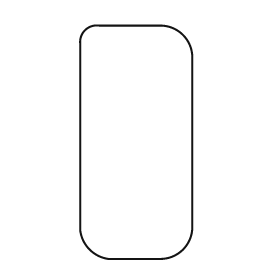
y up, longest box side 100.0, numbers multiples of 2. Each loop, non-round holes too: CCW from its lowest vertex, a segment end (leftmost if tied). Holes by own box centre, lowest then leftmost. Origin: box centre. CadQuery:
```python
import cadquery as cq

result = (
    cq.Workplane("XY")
    .moveTo(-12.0, -50.0)
    .lineTo(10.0, -50.0)
    .threePointArc((20.0, -46.0), (24.0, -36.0))
    .lineTo(24.0, 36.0)
    .threePointArc((20.0, 46.0), (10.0, 50.0))
    .lineTo(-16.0, 50.0)
    .threePointArc((-22.0, 48.0), (-24.0, 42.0))
    .lineTo(-24.0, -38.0)
    .threePointArc((-20.0, -46.0), (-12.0, -50.0))
    .close()
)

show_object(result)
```